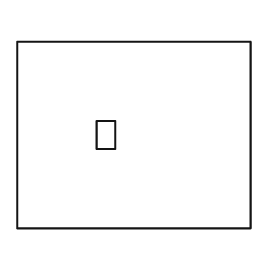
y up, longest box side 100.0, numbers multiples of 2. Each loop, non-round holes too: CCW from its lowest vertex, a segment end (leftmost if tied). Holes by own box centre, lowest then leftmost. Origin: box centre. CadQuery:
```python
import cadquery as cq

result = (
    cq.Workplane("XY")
    .moveTo(-50.0, -40.0)
    .lineTo(50.0, -40.0)
    .lineTo(50.0, 40.0)
    .lineTo(-50.0, 40.0)
    .close()
    .moveTo(-16.0, -6.0)
    .lineTo(-8.0, -6.0)
    .lineTo(-8.0, 6.0)
    .lineTo(-16.0, 6.0)
    .close()
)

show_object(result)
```